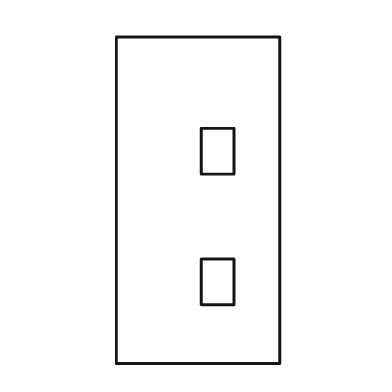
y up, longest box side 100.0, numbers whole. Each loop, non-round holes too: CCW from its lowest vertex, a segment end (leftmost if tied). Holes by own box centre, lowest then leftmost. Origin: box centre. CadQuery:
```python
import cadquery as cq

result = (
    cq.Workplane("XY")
    .moveTo(-25.0, -50.0)
    .lineTo(25.0, -50.0)
    .lineTo(25.0, 50.0)
    .lineTo(-25.0, 50.0)
    .close()
    .moveTo(1.0, -32.0)
    .lineTo(11.0, -32.0)
    .lineTo(11.0, -18.0)
    .lineTo(1.0, -18.0)
    .close()
    .moveTo(1.0, 8.0)
    .lineTo(11.0, 8.0)
    .lineTo(11.0, 22.0)
    .lineTo(1.0, 22.0)
    .close()
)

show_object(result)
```